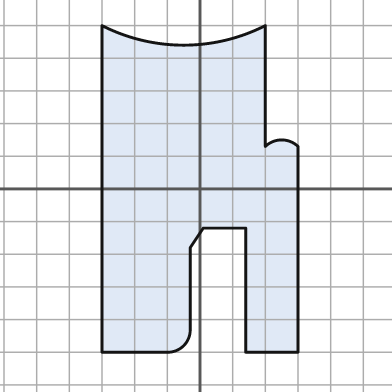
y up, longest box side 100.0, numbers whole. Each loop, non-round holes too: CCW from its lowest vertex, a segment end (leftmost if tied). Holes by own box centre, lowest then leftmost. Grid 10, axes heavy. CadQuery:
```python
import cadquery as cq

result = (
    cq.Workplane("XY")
    .moveTo(-30.0, -50.0)
    .lineTo(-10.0, -50.0)
    .threePointArc((-5.0, -48.0), (-3.0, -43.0))
    .lineTo(-3.0, -18.0)
    .lineTo(1.0, -12.0)
    .lineTo(14.0, -12.0)
    .lineTo(14.0, -50.0)
    .lineTo(30.0, -50.0)
    .lineTo(30.0, 13.0)
    .threePointArc((25.0, 15.0), (20.0, 13.0))
    .lineTo(20.0, 50.0)
    .threePointArc((-5.0, 44.0), (-30.0, 50.0))
    .close()
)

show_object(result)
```